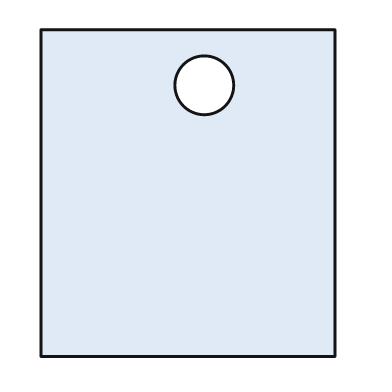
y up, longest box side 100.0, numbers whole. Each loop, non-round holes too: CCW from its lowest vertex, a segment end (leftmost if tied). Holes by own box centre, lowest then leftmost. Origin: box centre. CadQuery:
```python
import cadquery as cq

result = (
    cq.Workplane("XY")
    .moveTo(-45.0, -50.0)
    .lineTo(45.0, -50.0)
    .lineTo(45.0, 50.0)
    .lineTo(-45.0, 50.0)
    .close()
    .moveTo(5.0, 33.0)
    .circle(9.0)
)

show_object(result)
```